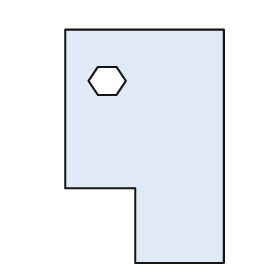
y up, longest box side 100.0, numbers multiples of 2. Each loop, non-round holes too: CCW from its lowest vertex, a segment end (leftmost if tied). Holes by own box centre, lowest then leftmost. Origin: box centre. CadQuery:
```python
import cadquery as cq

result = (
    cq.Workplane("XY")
    .moveTo(-4.0, -50.0)
    .lineTo(34.0, -50.0)
    .lineTo(34.0, 50.0)
    .lineTo(-34.0, 50.0)
    .lineTo(-34.0, -18.0)
    .lineTo(-4.0, -18.0)
    .close()
    .moveTo(-20.0, 22.0)
    .lineTo(-12.0, 22.0)
    .lineTo(-8.0, 28.0)
    .lineTo(-12.0, 34.0)
    .lineTo(-20.0, 34.0)
    .lineTo(-24.0, 28.0)
    .close()
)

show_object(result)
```